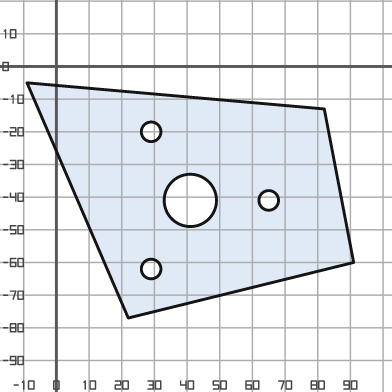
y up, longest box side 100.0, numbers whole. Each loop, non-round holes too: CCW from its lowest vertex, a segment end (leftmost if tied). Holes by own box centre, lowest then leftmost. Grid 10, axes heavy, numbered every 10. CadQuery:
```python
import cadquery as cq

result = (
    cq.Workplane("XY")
    .moveTo(22.0, -77.0)
    .lineTo(91.0, -60.0)
    .lineTo(82.0, -13.0)
    .lineTo(-9.0, -5.0)
    .close()
    .moveTo(29.0, -62.0)
    .circle(3.0)
    .moveTo(41.0, -41.0)
    .circle(8.0)
    .moveTo(65.0, -41.0)
    .circle(3.0)
    .moveTo(29.0, -20.0)
    .circle(3.0)
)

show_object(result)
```